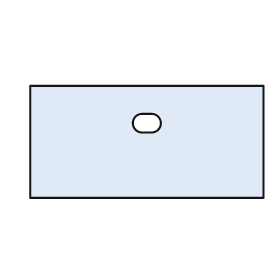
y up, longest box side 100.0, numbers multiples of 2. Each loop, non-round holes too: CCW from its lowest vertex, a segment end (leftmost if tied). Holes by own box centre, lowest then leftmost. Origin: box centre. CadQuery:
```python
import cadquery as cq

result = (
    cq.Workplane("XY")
    .moveTo(-50.0, -24.0)
    .lineTo(50.0, -24.0)
    .lineTo(50.0, 24.0)
    .lineTo(-50.0, 24.0)
    .close()
    .moveTo(-2.0, 4.0)
    .lineTo(2.0, 4.0)
    .threePointArc((6.0, 8.0), (2.0, 12.0))
    .lineTo(-2.0, 12.0)
    .threePointArc((-6.0, 8.0), (-2.0, 4.0))
    .close()
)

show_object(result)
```